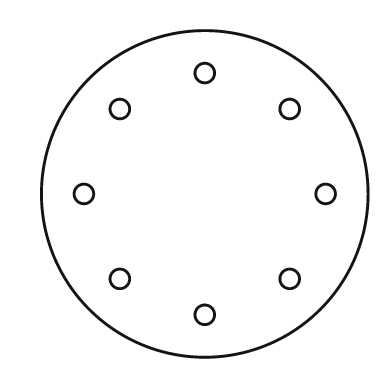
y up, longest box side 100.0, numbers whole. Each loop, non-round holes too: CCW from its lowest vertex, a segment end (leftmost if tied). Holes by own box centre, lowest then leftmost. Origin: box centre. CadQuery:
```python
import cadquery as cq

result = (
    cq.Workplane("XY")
    .moveTo(0.0, 0.0)
    .circle(50.0)
    .moveTo(0.0, -37.0)
    .circle(3.0)
    .moveTo(-26.0, -26.0)
    .circle(3.0)
    .moveTo(26.0, -26.0)
    .circle(3.0)
    .moveTo(-37.0, 0.0)
    .circle(3.0)
    .moveTo(37.0, 0.0)
    .circle(3.0)
    .moveTo(-26.0, 26.0)
    .circle(3.0)
    .moveTo(26.0, 26.0)
    .circle(3.0)
    .moveTo(0.0, 37.0)
    .circle(3.0)
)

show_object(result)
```